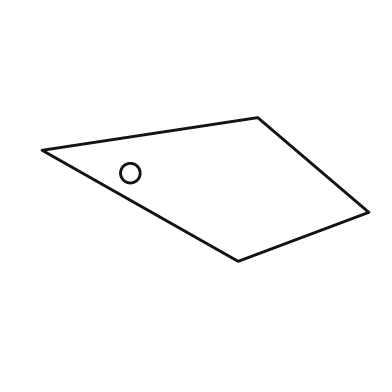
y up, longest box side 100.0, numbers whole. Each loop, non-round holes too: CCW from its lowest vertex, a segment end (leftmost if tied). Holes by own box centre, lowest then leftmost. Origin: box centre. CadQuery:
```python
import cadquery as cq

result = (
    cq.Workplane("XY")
    .moveTo(10.0, -22.0)
    .lineTo(50.0, -7.0)
    .lineTo(16.0, 22.0)
    .lineTo(-50.0, 12.0)
    .close()
    .moveTo(-23.0, 5.0)
    .circle(3.0)
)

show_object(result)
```